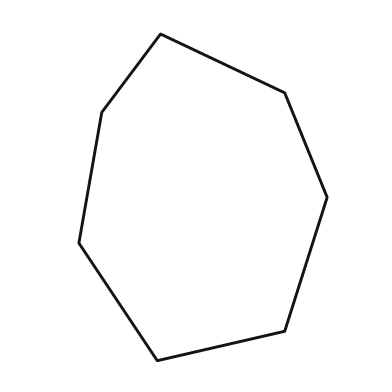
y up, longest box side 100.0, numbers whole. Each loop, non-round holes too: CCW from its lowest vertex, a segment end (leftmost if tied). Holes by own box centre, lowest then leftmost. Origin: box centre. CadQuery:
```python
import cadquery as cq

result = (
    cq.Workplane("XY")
    .moveTo(-14.0, -50.0)
    .lineTo(25.0, -41.0)
    .lineTo(38.0, 0.0)
    .lineTo(25.0, 32.0)
    .lineTo(-13.0, 50.0)
    .lineTo(-31.0, 26.0)
    .lineTo(-38.0, -14.0)
    .close()
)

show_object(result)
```